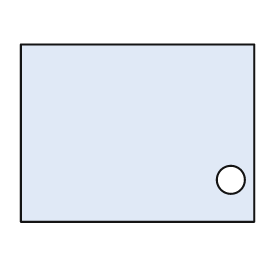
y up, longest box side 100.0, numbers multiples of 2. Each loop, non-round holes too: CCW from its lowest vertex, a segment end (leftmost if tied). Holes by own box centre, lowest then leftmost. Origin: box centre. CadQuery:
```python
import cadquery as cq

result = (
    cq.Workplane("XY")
    .moveTo(-50.0, -38.0)
    .lineTo(50.0, -38.0)
    .lineTo(50.0, 38.0)
    .lineTo(-50.0, 38.0)
    .close()
    .moveTo(40.0, -20.0)
    .circle(6.0)
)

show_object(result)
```